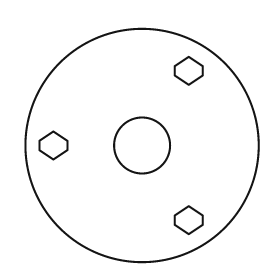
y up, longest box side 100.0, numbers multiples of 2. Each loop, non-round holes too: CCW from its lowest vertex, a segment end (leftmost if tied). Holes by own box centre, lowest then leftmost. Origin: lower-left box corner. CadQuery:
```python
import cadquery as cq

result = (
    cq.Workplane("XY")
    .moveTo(50.0, 50.0)
    .circle(50.0)
    .moveTo(70.0, 12.0)
    .lineTo(76.0, 16.0)
    .lineTo(76.0, 20.0)
    .lineTo(70.0, 24.0)
    .lineTo(64.0, 20.0)
    .lineTo(64.0, 16.0)
    .close()
    .moveTo(12.0, 44.0)
    .lineTo(18.0, 48.0)
    .lineTo(18.0, 52.0)
    .lineTo(12.0, 56.0)
    .lineTo(6.0, 52.0)
    .lineTo(6.0, 48.0)
    .close()
    .moveTo(50.0, 50.0)
    .circle(12.0)
    .moveTo(70.0, 76.0)
    .lineTo(76.0, 80.0)
    .lineTo(76.0, 84.0)
    .lineTo(70.0, 88.0)
    .lineTo(64.0, 84.0)
    .lineTo(64.0, 80.0)
    .close()
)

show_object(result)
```